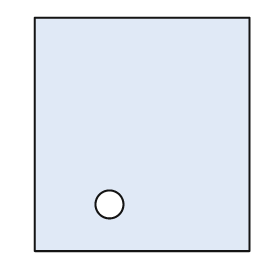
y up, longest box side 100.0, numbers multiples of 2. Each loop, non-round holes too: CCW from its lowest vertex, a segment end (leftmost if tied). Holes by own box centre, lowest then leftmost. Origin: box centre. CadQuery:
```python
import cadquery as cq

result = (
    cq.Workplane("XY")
    .moveTo(-46.0, -50.0)
    .lineTo(46.0, -50.0)
    .lineTo(46.0, 50.0)
    .lineTo(-46.0, 50.0)
    .close()
    .moveTo(-14.0, -30.0)
    .circle(6.0)
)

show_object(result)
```